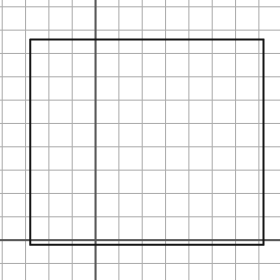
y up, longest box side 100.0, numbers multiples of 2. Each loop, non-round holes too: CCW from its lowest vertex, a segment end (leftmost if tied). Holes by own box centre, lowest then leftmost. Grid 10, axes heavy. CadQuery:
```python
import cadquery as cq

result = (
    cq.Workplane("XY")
    .moveTo(-28.0, -2.0)
    .lineTo(72.0, -2.0)
    .lineTo(72.0, 86.0)
    .lineTo(-28.0, 86.0)
    .close()
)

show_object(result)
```